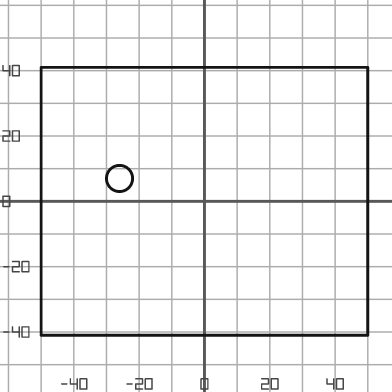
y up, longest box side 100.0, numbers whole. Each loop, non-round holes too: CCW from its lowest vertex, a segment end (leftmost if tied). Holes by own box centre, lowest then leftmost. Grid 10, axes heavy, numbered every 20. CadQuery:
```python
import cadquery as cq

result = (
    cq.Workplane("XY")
    .moveTo(-50.0, -41.0)
    .lineTo(50.0, -41.0)
    .lineTo(50.0, 41.0)
    .lineTo(-50.0, 41.0)
    .close()
    .moveTo(-26.0, 7.0)
    .circle(4.0)
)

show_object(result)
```